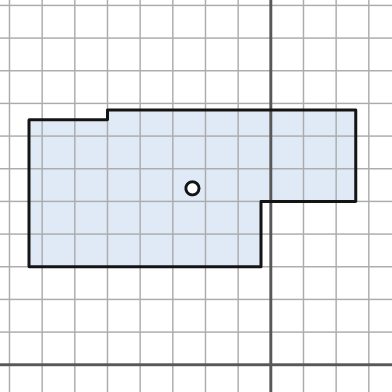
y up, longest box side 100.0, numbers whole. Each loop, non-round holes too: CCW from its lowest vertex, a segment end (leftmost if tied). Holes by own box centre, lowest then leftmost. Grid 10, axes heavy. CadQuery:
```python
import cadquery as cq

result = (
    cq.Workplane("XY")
    .moveTo(-74.0, 30.0)
    .lineTo(-3.0, 30.0)
    .lineTo(-3.0, 50.0)
    .lineTo(26.0, 50.0)
    .lineTo(26.0, 78.0)
    .lineTo(-50.0, 78.0)
    .lineTo(-50.0, 75.0)
    .lineTo(-74.0, 75.0)
    .close()
    .moveTo(-24.0, 54.0)
    .circle(2.0)
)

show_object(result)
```